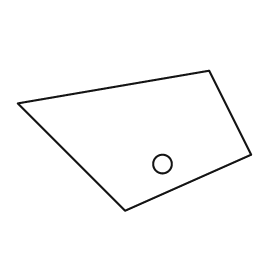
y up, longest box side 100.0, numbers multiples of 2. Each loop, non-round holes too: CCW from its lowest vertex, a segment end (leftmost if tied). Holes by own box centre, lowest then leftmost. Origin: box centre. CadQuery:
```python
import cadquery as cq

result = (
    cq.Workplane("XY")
    .moveTo(-4.0, -30.0)
    .lineTo(50.0, -6.0)
    .lineTo(32.0, 30.0)
    .lineTo(-50.0, 16.0)
    .close()
    .moveTo(12.0, -10.0)
    .circle(4.0)
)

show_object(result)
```